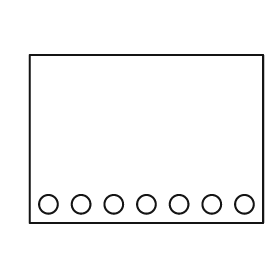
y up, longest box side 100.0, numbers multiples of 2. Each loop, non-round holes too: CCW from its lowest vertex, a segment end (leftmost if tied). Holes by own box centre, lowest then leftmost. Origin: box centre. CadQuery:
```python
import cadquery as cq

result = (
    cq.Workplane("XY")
    .moveTo(-50.0, -36.0)
    .lineTo(50.0, -36.0)
    .lineTo(50.0, 36.0)
    .lineTo(-50.0, 36.0)
    .close()
    .moveTo(-42.0, -28.0)
    .circle(4.0)
    .moveTo(-28.0, -28.0)
    .circle(4.0)
    .moveTo(-14.0, -28.0)
    .circle(4.0)
    .moveTo(0.0, -28.0)
    .circle(4.0)
    .moveTo(14.0, -28.0)
    .circle(4.0)
    .moveTo(28.0, -28.0)
    .circle(4.0)
    .moveTo(42.0, -28.0)
    .circle(4.0)
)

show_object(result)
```